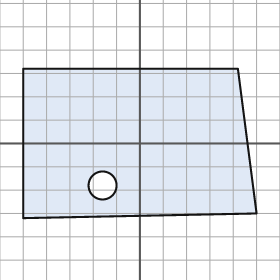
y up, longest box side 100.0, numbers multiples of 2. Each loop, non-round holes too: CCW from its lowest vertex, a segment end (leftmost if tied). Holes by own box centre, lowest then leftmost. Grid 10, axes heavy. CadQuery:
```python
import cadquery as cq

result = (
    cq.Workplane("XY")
    .moveTo(-50.0, -32.0)
    .lineTo(50.0, -30.0)
    .lineTo(42.0, 32.0)
    .lineTo(-50.0, 32.0)
    .close()
    .moveTo(-16.0, -18.0)
    .circle(6.0)
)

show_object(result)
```